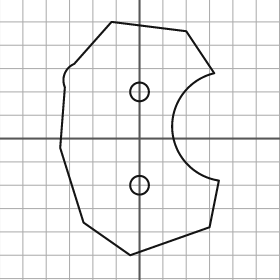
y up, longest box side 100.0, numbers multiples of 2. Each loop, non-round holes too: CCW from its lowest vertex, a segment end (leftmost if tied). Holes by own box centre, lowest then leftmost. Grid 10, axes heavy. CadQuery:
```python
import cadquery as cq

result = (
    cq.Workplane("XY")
    .moveTo(-4.0, -50.0)
    .lineTo(30.0, -38.0)
    .lineTo(34.0, -18.0)
    .threePointArc((14.0, 4.0), (32.0, 28.0))
    .lineTo(20.0, 46.0)
    .lineTo(-12.0, 50.0)
    .lineTo(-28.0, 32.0)
    .threePointArc((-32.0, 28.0), (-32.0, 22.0))
    .lineTo(-34.0, -4.0)
    .lineTo(-24.0, -36.0)
    .close()
    .moveTo(0.0, -20.0)
    .circle(4.0)
    .moveTo(0.0, 20.0)
    .circle(4.0)
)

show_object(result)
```